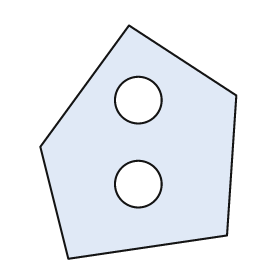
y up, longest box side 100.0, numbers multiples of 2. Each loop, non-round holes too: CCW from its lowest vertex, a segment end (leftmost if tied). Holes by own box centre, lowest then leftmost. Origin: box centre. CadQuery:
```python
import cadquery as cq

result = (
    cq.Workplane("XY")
    .moveTo(-30.0, -50.0)
    .lineTo(38.0, -40.0)
    .lineTo(42.0, 20.0)
    .lineTo(-4.0, 50.0)
    .lineTo(-42.0, -2.0)
    .close()
    .moveTo(0.0, -18.0)
    .circle(10.0)
    .moveTo(0.0, 18.0)
    .circle(10.0)
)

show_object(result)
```